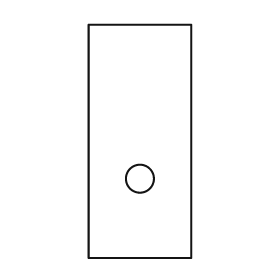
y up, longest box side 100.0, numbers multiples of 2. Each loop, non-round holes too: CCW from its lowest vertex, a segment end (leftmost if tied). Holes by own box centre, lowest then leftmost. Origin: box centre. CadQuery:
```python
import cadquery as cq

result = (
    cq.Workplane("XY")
    .moveTo(-22.0, -50.0)
    .lineTo(22.0, -50.0)
    .lineTo(22.0, 50.0)
    .lineTo(-22.0, 50.0)
    .close()
    .moveTo(0.0, -16.0)
    .circle(6.0)
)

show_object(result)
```